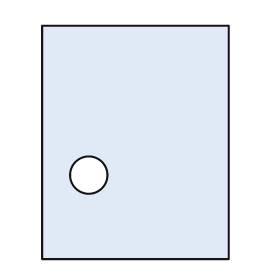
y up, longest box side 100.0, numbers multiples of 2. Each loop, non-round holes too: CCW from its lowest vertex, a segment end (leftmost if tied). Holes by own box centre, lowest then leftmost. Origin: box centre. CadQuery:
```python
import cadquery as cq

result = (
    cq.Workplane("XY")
    .moveTo(-40.0, -50.0)
    .lineTo(40.0, -50.0)
    .lineTo(40.0, 50.0)
    .lineTo(-40.0, 50.0)
    .close()
    .moveTo(-20.0, -14.0)
    .circle(8.0)
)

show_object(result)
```